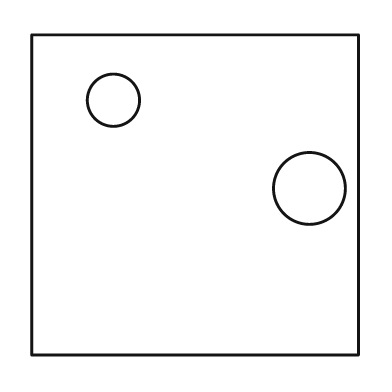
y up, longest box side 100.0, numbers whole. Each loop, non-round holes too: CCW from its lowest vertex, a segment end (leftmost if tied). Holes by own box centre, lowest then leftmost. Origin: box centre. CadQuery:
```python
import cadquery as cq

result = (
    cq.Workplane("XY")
    .moveTo(-50.0, -49.0)
    .lineTo(50.0, -49.0)
    .lineTo(50.0, 49.0)
    .lineTo(-50.0, 49.0)
    .close()
    .moveTo(35.0, 2.0)
    .circle(11.0)
    .moveTo(-25.0, 29.0)
    .circle(8.0)
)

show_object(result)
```